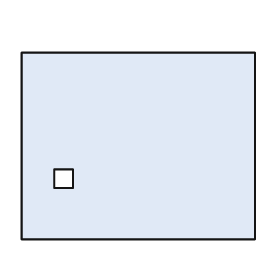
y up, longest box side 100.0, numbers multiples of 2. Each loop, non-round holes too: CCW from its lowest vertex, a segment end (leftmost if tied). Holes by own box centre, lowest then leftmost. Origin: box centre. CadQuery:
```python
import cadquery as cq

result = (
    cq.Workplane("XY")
    .moveTo(-50.0, -40.0)
    .lineTo(50.0, -40.0)
    .lineTo(50.0, 40.0)
    .lineTo(-50.0, 40.0)
    .close()
    .moveTo(-36.0, -18.0)
    .lineTo(-28.0, -18.0)
    .lineTo(-28.0, -10.0)
    .lineTo(-36.0, -10.0)
    .close()
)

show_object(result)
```